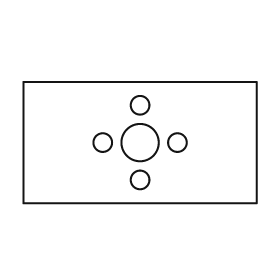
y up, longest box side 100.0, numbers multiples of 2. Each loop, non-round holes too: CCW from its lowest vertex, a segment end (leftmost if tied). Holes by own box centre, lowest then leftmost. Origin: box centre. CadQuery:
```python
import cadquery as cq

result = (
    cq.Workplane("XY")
    .moveTo(-50.0, -26.0)
    .lineTo(50.0, -26.0)
    .lineTo(50.0, 26.0)
    .lineTo(-50.0, 26.0)
    .close()
    .moveTo(0.0, -16.0)
    .circle(4.0)
    .moveTo(-16.0, 0.0)
    .circle(4.0)
    .moveTo(0.0, 0.0)
    .circle(8.0)
    .moveTo(16.0, 0.0)
    .circle(4.0)
    .moveTo(0.0, 16.0)
    .circle(4.0)
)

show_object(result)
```